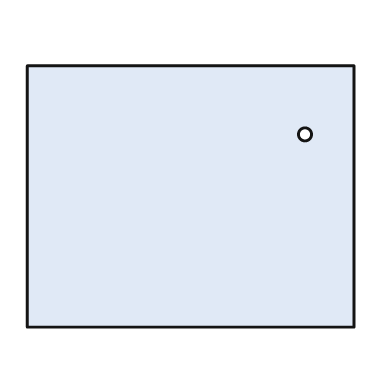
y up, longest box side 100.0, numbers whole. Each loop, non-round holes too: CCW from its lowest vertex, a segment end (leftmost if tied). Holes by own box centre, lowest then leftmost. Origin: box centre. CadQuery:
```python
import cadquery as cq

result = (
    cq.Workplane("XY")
    .moveTo(-50.0, -40.0)
    .lineTo(50.0, -40.0)
    .lineTo(50.0, 40.0)
    .lineTo(-50.0, 40.0)
    .close()
    .moveTo(35.0, 19.0)
    .circle(2.0)
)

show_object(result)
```